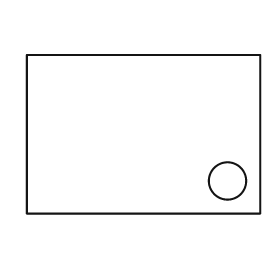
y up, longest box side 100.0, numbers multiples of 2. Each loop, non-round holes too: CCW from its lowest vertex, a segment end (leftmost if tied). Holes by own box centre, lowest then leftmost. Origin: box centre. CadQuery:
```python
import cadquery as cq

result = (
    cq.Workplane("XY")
    .moveTo(-50.0, -34.0)
    .lineTo(50.0, -34.0)
    .lineTo(50.0, 34.0)
    .lineTo(-50.0, 34.0)
    .close()
    .moveTo(36.0, -20.0)
    .circle(8.0)
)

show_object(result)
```